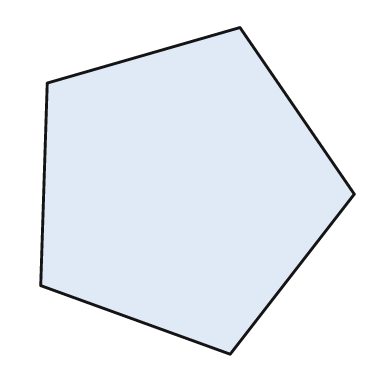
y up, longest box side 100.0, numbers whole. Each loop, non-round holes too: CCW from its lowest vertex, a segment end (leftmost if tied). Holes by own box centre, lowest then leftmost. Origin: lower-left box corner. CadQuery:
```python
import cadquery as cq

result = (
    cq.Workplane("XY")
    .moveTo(58.0, 0.0)
    .lineTo(96.0, 49.0)
    .lineTo(61.0, 100.0)
    .lineTo(2.0, 83.0)
    .lineTo(0.0, 21.0)
    .close()
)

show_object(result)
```